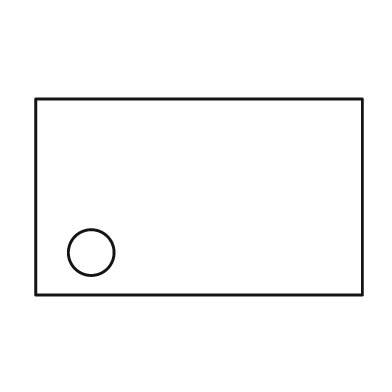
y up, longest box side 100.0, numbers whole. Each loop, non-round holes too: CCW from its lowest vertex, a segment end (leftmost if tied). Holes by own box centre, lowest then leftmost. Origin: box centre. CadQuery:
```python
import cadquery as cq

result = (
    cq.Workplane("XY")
    .moveTo(-50.0, -30.0)
    .lineTo(50.0, -30.0)
    .lineTo(50.0, 30.0)
    .lineTo(-50.0, 30.0)
    .close()
    .moveTo(-33.0, -17.0)
    .circle(7.0)
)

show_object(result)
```